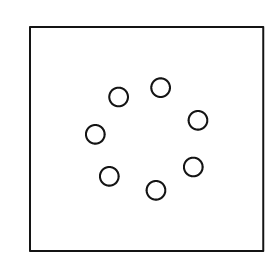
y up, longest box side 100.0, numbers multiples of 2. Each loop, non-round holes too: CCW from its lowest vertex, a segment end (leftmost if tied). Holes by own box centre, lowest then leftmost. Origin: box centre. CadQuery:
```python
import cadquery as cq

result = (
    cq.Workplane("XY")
    .moveTo(-50.0, -48.0)
    .lineTo(50.0, -48.0)
    .lineTo(50.0, 48.0)
    .lineTo(-50.0, 48.0)
    .close()
    .moveTo(4.0, -22.0)
    .circle(4.0)
    .moveTo(-16.0, -16.0)
    .circle(4.0)
    .moveTo(20.0, -12.0)
    .circle(4.0)
    .moveTo(-22.0, 2.0)
    .circle(4.0)
    .moveTo(22.0, 8.0)
    .circle(4.0)
    .moveTo(-12.0, 18.0)
    .circle(4.0)
    .moveTo(6.0, 22.0)
    .circle(4.0)
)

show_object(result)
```